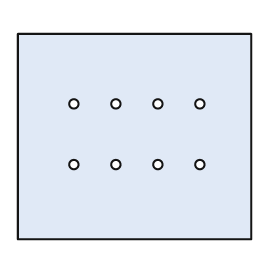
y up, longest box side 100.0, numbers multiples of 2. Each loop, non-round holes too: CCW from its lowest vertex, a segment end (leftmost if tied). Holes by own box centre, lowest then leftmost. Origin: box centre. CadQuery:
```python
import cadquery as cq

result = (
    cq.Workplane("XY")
    .moveTo(-50.0, -44.0)
    .lineTo(50.0, -44.0)
    .lineTo(50.0, 44.0)
    .lineTo(-50.0, 44.0)
    .close()
    .moveTo(-26.0, -12.0)
    .circle(2.0)
    .moveTo(-8.0, -12.0)
    .circle(2.0)
    .moveTo(10.0, -12.0)
    .circle(2.0)
    .moveTo(28.0, -12.0)
    .circle(2.0)
    .moveTo(-26.0, 14.0)
    .circle(2.0)
    .moveTo(-8.0, 14.0)
    .circle(2.0)
    .moveTo(10.0, 14.0)
    .circle(2.0)
    .moveTo(28.0, 14.0)
    .circle(2.0)
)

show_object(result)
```